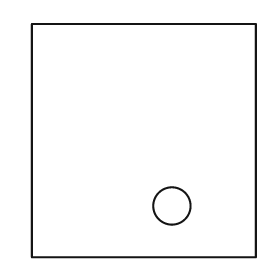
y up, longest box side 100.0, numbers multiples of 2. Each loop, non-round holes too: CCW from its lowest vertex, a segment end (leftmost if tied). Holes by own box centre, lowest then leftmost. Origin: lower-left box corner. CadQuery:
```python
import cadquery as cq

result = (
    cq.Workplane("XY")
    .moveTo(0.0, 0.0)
    .lineTo(96.0, 0.0)
    .lineTo(96.0, 100.0)
    .lineTo(0.0, 100.0)
    .close()
    .moveTo(60.0, 22.0)
    .circle(8.0)
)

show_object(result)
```